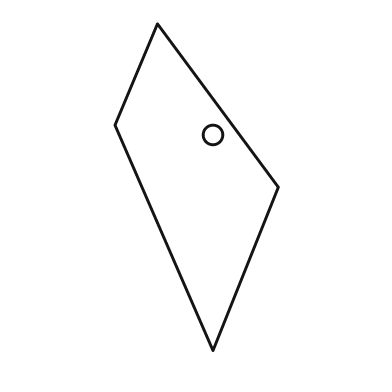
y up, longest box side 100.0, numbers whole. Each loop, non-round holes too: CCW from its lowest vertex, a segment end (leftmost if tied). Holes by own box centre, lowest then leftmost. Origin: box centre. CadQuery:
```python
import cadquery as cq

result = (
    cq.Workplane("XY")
    .moveTo(5.0, -50.0)
    .lineTo(25.0, 0.0)
    .lineTo(-12.0, 50.0)
    .lineTo(-25.0, 19.0)
    .close()
    .moveTo(5.0, 16.0)
    .circle(3.0)
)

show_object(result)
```